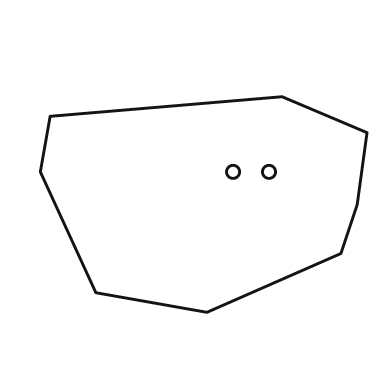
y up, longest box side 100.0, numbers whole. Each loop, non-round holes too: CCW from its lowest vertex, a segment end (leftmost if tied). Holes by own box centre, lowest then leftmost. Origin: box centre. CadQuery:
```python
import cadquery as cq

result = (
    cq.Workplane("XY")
    .moveTo(1.0, -33.0)
    .lineTo(42.0, -15.0)
    .lineTo(47.0, 0.0)
    .lineTo(50.0, 22.0)
    .lineTo(24.0, 33.0)
    .lineTo(-47.0, 27.0)
    .lineTo(-50.0, 10.0)
    .lineTo(-33.0, -27.0)
    .close()
    .moveTo(9.0, 10.0)
    .circle(2.0)
    .moveTo(20.0, 10.0)
    .circle(2.0)
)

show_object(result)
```